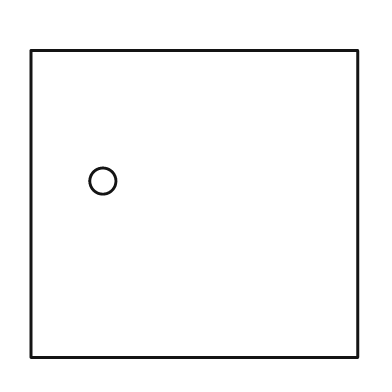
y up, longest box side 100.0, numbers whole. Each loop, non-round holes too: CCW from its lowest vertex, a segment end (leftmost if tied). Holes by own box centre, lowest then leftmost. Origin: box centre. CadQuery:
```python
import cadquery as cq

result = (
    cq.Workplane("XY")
    .moveTo(-50.0, -47.0)
    .lineTo(50.0, -47.0)
    .lineTo(50.0, 47.0)
    .lineTo(-50.0, 47.0)
    .close()
    .moveTo(-28.0, 7.0)
    .circle(4.0)
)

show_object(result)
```